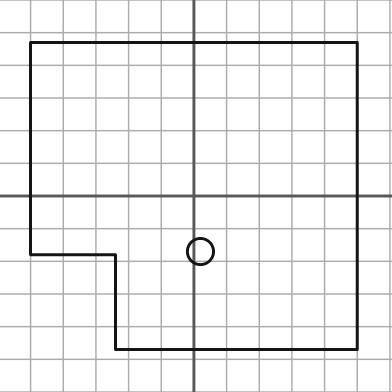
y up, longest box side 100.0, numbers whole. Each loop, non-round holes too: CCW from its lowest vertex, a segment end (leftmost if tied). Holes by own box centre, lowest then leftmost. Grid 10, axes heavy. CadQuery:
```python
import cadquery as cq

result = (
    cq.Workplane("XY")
    .moveTo(-24.0, -47.0)
    .lineTo(50.0, -47.0)
    .lineTo(50.0, 47.0)
    .lineTo(-50.0, 47.0)
    .lineTo(-50.0, -18.0)
    .lineTo(-24.0, -18.0)
    .close()
    .moveTo(2.0, -17.0)
    .circle(4.0)
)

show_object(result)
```